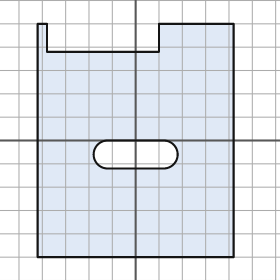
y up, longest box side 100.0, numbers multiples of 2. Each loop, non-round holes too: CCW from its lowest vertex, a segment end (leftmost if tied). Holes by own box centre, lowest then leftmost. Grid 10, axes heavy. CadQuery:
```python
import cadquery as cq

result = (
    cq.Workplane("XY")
    .moveTo(-42.0, -50.0)
    .lineTo(42.0, -50.0)
    .lineTo(42.0, 50.0)
    .lineTo(10.0, 50.0)
    .lineTo(10.0, 38.0)
    .lineTo(-38.0, 38.0)
    .lineTo(-38.0, 50.0)
    .lineTo(-42.0, 50.0)
    .close()
    .moveTo(-12.0, -12.0)
    .lineTo(12.0, -12.0)
    .threePointArc((18.0, -6.0), (12.0, 0.0))
    .lineTo(-12.0, 0.0)
    .threePointArc((-18.0, -6.0), (-12.0, -12.0))
    .close()
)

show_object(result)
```